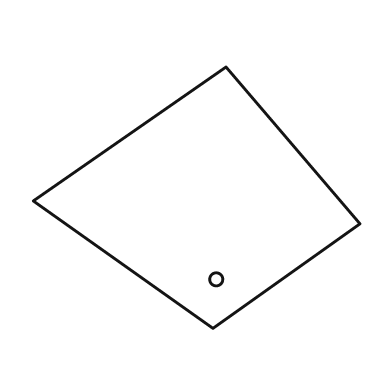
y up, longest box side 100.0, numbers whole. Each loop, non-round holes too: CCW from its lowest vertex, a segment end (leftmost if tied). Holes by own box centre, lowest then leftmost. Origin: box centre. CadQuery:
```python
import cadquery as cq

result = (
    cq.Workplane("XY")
    .moveTo(5.0, -40.0)
    .lineTo(50.0, -8.0)
    .lineTo(9.0, 40.0)
    .lineTo(-50.0, -1.0)
    .close()
    .moveTo(6.0, -25.0)
    .circle(2.0)
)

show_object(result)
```